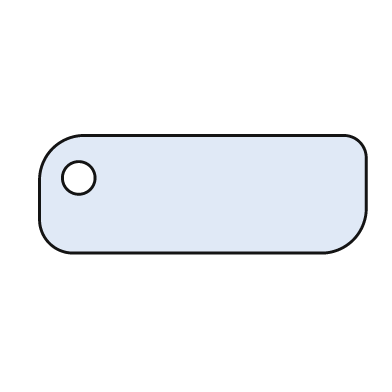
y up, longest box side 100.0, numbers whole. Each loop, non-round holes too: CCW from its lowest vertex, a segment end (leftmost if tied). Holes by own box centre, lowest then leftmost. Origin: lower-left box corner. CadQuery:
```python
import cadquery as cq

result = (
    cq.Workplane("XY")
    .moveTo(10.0, 0.0)
    .lineTo(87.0, 0.0)
    .threePointArc((96.0, 4.0), (100.0, 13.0))
    .lineTo(100.0, 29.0)
    .threePointArc((98.0, 34.0), (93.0, 36.0))
    .lineTo(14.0, 36.0)
    .threePointArc((4.0, 32.0), (0.0, 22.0))
    .lineTo(0.0, 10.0)
    .threePointArc((3.0, 3.0), (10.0, 0.0))
    .close()
    .moveTo(12.0, 23.0)
    .circle(5.0)
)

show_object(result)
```